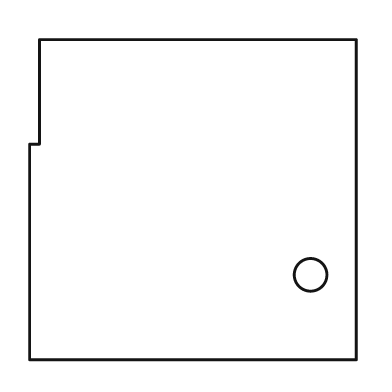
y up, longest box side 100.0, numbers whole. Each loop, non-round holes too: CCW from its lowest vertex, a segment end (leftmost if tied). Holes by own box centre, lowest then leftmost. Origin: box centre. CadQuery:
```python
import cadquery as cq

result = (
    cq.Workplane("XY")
    .moveTo(-50.0, -49.0)
    .lineTo(50.0, -49.0)
    .lineTo(50.0, 49.0)
    .lineTo(-47.0, 49.0)
    .lineTo(-47.0, 17.0)
    .lineTo(-50.0, 17.0)
    .close()
    .moveTo(36.0, -23.0)
    .circle(5.0)
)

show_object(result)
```